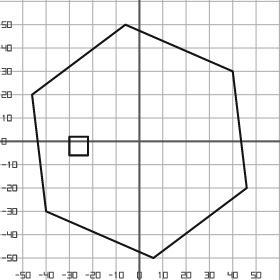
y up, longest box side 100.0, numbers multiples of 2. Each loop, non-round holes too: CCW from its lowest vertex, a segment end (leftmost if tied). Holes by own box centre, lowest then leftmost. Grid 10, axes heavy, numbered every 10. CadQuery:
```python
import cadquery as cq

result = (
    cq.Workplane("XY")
    .moveTo(6.0, -50.0)
    .lineTo(46.0, -20.0)
    .lineTo(40.0, 30.0)
    .lineTo(-6.0, 50.0)
    .lineTo(-46.0, 20.0)
    .lineTo(-40.0, -30.0)
    .close()
    .moveTo(-30.0, -6.0)
    .lineTo(-22.0, -6.0)
    .lineTo(-22.0, 2.0)
    .lineTo(-30.0, 2.0)
    .close()
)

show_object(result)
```